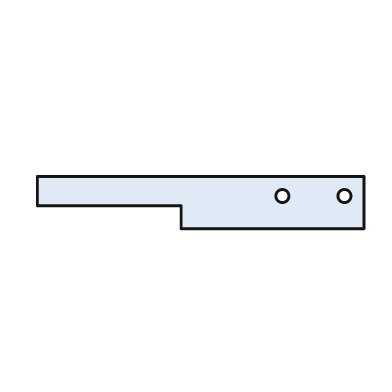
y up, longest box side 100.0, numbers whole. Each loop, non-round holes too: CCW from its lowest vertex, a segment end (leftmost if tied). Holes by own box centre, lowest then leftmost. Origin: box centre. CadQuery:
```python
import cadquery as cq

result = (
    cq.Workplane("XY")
    .moveTo(-6.0, -8.0)
    .lineTo(50.0, -8.0)
    .lineTo(50.0, 8.0)
    .lineTo(-50.0, 8.0)
    .lineTo(-50.0, -1.0)
    .lineTo(-6.0, -1.0)
    .close()
    .moveTo(25.0, 2.0)
    .circle(2.0)
    .moveTo(44.0, 2.0)
    .circle(2.0)
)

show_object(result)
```